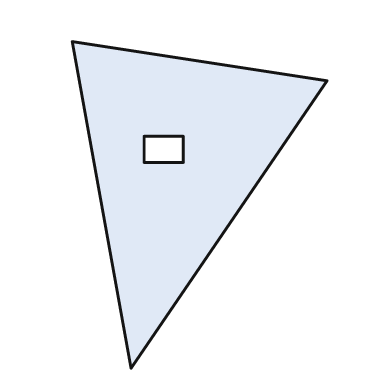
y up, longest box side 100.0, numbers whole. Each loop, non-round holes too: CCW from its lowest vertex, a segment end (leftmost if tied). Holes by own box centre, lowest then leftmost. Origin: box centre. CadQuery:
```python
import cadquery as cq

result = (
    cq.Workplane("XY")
    .moveTo(-21.0, -50.0)
    .lineTo(39.0, 38.0)
    .lineTo(-39.0, 50.0)
    .close()
    .moveTo(-17.0, 13.0)
    .lineTo(-5.0, 13.0)
    .lineTo(-5.0, 21.0)
    .lineTo(-17.0, 21.0)
    .close()
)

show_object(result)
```